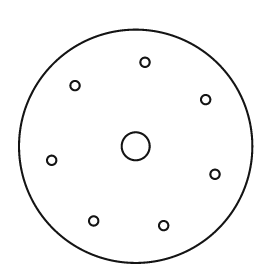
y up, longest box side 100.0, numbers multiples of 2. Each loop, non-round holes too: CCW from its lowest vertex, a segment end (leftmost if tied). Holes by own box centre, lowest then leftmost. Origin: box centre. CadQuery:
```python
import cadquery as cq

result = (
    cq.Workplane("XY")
    .moveTo(0.0, 0.0)
    .circle(50.0)
    .moveTo(12.0, -34.0)
    .circle(2.0)
    .moveTo(-18.0, -32.0)
    .circle(2.0)
    .moveTo(34.0, -12.0)
    .circle(2.0)
    .moveTo(-36.0, -6.0)
    .circle(2.0)
    .moveTo(0.0, 0.0)
    .circle(6.0)
    .moveTo(30.0, 20.0)
    .circle(2.0)
    .moveTo(-26.0, 26.0)
    .circle(2.0)
    .moveTo(4.0, 36.0)
    .circle(2.0)
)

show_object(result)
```